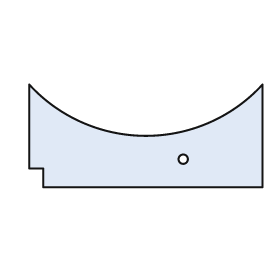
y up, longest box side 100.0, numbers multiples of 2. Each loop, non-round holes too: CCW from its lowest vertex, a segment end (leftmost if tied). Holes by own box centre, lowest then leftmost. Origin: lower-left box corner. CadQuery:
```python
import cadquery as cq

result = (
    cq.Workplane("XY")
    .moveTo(6.0, 0.0)
    .lineTo(100.0, 0.0)
    .lineTo(100.0, 44.0)
    .threePointArc((50.0, 22.0), (0.0, 44.0))
    .lineTo(0.0, 8.0)
    .lineTo(6.0, 8.0)
    .close()
    .moveTo(66.0, 12.0)
    .circle(2.0)
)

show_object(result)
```